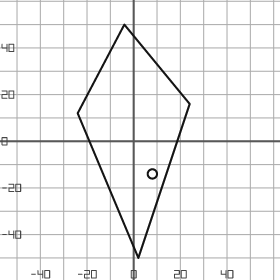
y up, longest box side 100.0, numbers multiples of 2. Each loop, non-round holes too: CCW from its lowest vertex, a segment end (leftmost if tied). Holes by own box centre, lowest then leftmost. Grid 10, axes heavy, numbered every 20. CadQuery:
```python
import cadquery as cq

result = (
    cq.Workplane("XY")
    .moveTo(2.0, -50.0)
    .lineTo(24.0, 16.0)
    .lineTo(-4.0, 50.0)
    .lineTo(-24.0, 12.0)
    .close()
    .moveTo(8.0, -14.0)
    .circle(2.0)
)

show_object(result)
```